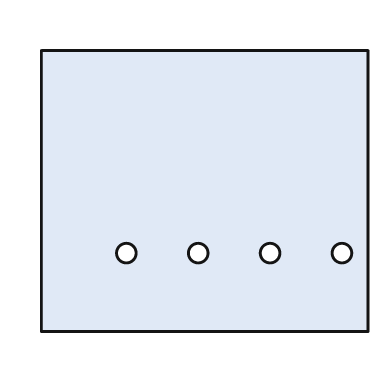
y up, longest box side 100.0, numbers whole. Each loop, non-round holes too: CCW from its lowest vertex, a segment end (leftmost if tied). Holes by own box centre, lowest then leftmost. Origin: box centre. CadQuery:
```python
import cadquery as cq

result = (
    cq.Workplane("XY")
    .moveTo(-50.0, -43.0)
    .lineTo(50.0, -43.0)
    .lineTo(50.0, 43.0)
    .lineTo(-50.0, 43.0)
    .close()
    .moveTo(-24.0, -19.0)
    .circle(3.0)
    .moveTo(-2.0, -19.0)
    .circle(3.0)
    .moveTo(20.0, -19.0)
    .circle(3.0)
    .moveTo(42.0, -19.0)
    .circle(3.0)
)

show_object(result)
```